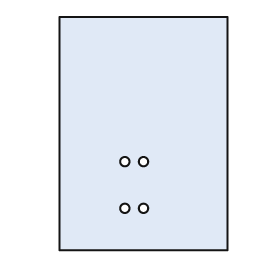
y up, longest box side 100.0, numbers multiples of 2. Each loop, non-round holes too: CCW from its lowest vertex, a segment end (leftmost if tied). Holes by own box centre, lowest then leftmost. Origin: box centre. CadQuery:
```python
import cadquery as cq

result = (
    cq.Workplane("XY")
    .moveTo(-36.0, -50.0)
    .lineTo(36.0, -50.0)
    .lineTo(36.0, 50.0)
    .lineTo(-36.0, 50.0)
    .close()
    .moveTo(-8.0, -32.0)
    .circle(2.0)
    .moveTo(0.0, -32.0)
    .circle(2.0)
    .moveTo(-8.0, -12.0)
    .circle(2.0)
    .moveTo(0.0, -12.0)
    .circle(2.0)
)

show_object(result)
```